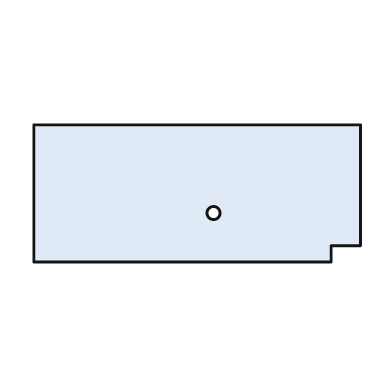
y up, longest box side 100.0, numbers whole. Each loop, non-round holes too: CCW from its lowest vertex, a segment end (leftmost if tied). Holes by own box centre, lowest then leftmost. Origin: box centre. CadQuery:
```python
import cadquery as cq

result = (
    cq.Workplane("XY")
    .moveTo(-50.0, -21.0)
    .lineTo(41.0, -21.0)
    .lineTo(41.0, -16.0)
    .lineTo(50.0, -16.0)
    .lineTo(50.0, 21.0)
    .lineTo(-50.0, 21.0)
    .close()
    .moveTo(5.0, -6.0)
    .circle(2.0)
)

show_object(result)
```